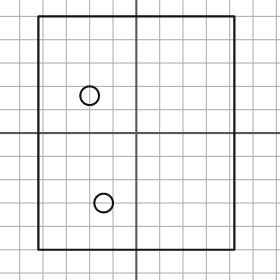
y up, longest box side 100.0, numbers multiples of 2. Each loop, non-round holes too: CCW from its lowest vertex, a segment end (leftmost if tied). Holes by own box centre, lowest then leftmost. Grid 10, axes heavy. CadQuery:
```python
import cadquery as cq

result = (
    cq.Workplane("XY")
    .moveTo(-42.0, -50.0)
    .lineTo(42.0, -50.0)
    .lineTo(42.0, 50.0)
    .lineTo(-42.0, 50.0)
    .close()
    .moveTo(-14.0, -30.0)
    .circle(4.0)
    .moveTo(-20.0, 16.0)
    .circle(4.0)
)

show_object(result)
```